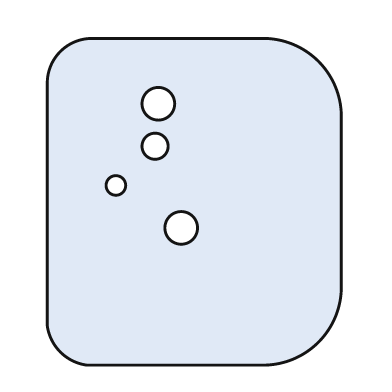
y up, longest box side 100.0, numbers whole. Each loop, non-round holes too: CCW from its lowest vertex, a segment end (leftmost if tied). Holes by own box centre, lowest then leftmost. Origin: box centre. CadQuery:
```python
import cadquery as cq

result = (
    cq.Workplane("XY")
    .moveTo(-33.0, -50.0)
    .lineTo(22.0, -50.0)
    .threePointArc((38.0, -43.0), (45.0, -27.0))
    .lineTo(45.0, 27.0)
    .threePointArc((38.0, 43.0), (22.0, 50.0))
    .lineTo(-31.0, 50.0)
    .threePointArc((-41.0, 46.0), (-45.0, 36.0))
    .lineTo(-45.0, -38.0)
    .threePointArc((-41.0, -46.0), (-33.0, -50.0))
    .close()
    .moveTo(-4.0, -8.0)
    .circle(5.0)
    .moveTo(-24.0, 5.0)
    .circle(3.0)
    .moveTo(-12.0, 17.0)
    .circle(4.0)
    .moveTo(-11.0, 30.0)
    .circle(5.0)
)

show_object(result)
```